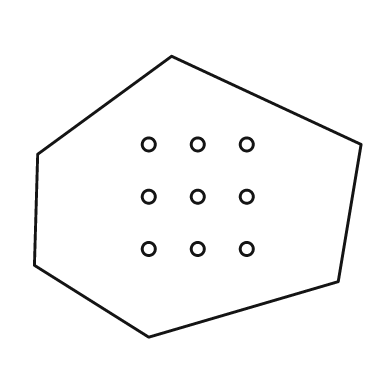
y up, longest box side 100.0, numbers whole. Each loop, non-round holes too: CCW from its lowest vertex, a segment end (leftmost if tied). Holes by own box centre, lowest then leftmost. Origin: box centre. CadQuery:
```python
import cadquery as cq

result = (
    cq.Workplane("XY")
    .moveTo(-15.0, -43.0)
    .lineTo(43.0, -26.0)
    .lineTo(50.0, 16.0)
    .lineTo(-8.0, 43.0)
    .lineTo(-49.0, 13.0)
    .lineTo(-50.0, -21.0)
    .close()
    .moveTo(-15.0, -16.0)
    .circle(2.0)
    .moveTo(0.0, -16.0)
    .circle(2.0)
    .moveTo(15.0, -16.0)
    .circle(2.0)
    .moveTo(-15.0, 0.0)
    .circle(2.0)
    .moveTo(0.0, 0.0)
    .circle(2.0)
    .moveTo(15.0, 0.0)
    .circle(2.0)
    .moveTo(-15.0, 16.0)
    .circle(2.0)
    .moveTo(0.0, 16.0)
    .circle(2.0)
    .moveTo(15.0, 16.0)
    .circle(2.0)
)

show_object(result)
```